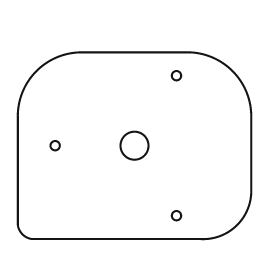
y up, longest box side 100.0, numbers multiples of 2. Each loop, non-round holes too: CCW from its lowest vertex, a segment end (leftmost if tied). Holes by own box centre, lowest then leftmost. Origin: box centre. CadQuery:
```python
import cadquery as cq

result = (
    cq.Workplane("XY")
    .moveTo(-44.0, -40.0)
    .lineTo(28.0, -40.0)
    .threePointArc((44.0, -34.0), (50.0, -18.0))
    .lineTo(50.0, 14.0)
    .threePointArc((42.0, 32.0), (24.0, 40.0))
    .lineTo(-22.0, 40.0)
    .threePointArc((-42.0, 32.0), (-50.0, 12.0))
    .lineTo(-50.0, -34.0)
    .threePointArc((-48.0, -38.0), (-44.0, -40.0))
    .close()
    .moveTo(18.0, -30.0)
    .circle(2.0)
    .moveTo(-34.0, 0.0)
    .circle(2.0)
    .moveTo(0.0, 0.0)
    .circle(6.0)
    .moveTo(18.0, 30.0)
    .circle(2.0)
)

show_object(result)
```